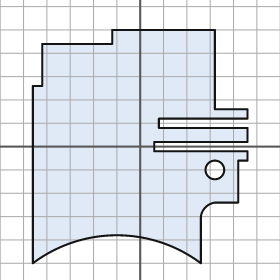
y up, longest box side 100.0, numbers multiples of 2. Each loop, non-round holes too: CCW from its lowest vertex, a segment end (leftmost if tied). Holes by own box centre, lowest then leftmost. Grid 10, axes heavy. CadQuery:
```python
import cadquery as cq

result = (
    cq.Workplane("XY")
    .moveTo(-46.0, -50.0)
    .threePointArc((-10.0, -38.0), (26.0, -50.0))
    .lineTo(26.0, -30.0)
    .threePointArc((28.0, -26.0), (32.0, -24.0))
    .lineTo(42.0, -24.0)
    .lineTo(42.0, -6.0)
    .lineTo(46.0, -6.0)
    .lineTo(46.0, -2.0)
    .lineTo(6.0, -2.0)
    .lineTo(6.0, 2.0)
    .lineTo(46.0, 2.0)
    .lineTo(46.0, 8.0)
    .lineTo(8.0, 8.0)
    .lineTo(8.0, 12.0)
    .lineTo(46.0, 12.0)
    .lineTo(46.0, 16.0)
    .lineTo(32.0, 16.0)
    .lineTo(32.0, 50.0)
    .lineTo(-12.0, 50.0)
    .lineTo(-12.0, 44.0)
    .lineTo(-42.0, 44.0)
    .lineTo(-42.0, 26.0)
    .lineTo(-46.0, 26.0)
    .close()
    .moveTo(32.0, -10.0)
    .circle(4.0)
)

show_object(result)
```